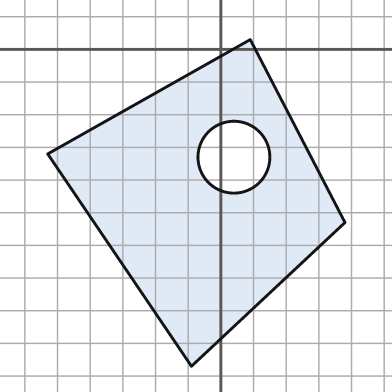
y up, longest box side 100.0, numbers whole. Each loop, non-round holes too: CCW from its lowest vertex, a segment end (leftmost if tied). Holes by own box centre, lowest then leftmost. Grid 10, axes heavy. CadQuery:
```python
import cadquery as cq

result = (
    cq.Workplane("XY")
    .moveTo(-9.0, -97.0)
    .lineTo(38.0, -53.0)
    .lineTo(9.0, 3.0)
    .lineTo(-53.0, -32.0)
    .close()
    .moveTo(4.0, -33.0)
    .circle(11.0)
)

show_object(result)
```